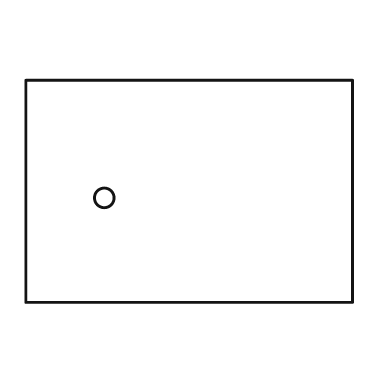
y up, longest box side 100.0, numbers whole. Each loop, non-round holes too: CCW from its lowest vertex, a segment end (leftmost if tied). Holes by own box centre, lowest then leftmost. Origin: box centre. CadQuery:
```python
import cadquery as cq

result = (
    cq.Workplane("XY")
    .moveTo(-50.0, -34.0)
    .lineTo(50.0, -34.0)
    .lineTo(50.0, 34.0)
    .lineTo(-50.0, 34.0)
    .close()
    .moveTo(-26.0, -2.0)
    .circle(3.0)
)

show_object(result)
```